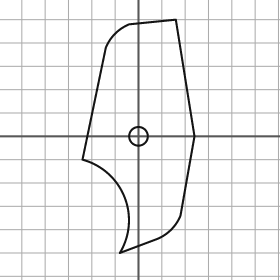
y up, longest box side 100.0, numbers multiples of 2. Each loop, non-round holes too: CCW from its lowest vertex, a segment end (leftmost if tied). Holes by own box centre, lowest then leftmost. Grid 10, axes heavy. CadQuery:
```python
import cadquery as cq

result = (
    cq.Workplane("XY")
    .moveTo(-8.0, -50.0)
    .lineTo(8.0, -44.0)
    .threePointArc((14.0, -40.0), (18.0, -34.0))
    .lineTo(24.0, 0.0)
    .lineTo(16.0, 50.0)
    .lineTo(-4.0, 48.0)
    .threePointArc((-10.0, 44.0), (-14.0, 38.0))
    .lineTo(-24.0, -10.0)
    .threePointArc((-6.0, -26.0), (-8.0, -50.0))
    .close()
    .moveTo(0.0, 0.0)
    .circle(4.0)
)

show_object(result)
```